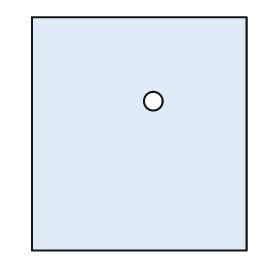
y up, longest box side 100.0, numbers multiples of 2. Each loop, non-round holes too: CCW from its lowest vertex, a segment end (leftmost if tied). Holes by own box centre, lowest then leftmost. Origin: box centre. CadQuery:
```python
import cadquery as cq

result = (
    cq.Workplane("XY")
    .moveTo(-46.0, -50.0)
    .lineTo(46.0, -50.0)
    .lineTo(46.0, 50.0)
    .lineTo(-46.0, 50.0)
    .close()
    .moveTo(6.0, 14.0)
    .circle(4.0)
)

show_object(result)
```